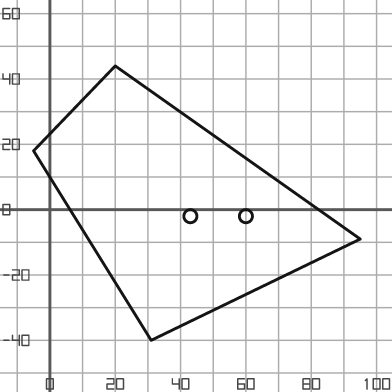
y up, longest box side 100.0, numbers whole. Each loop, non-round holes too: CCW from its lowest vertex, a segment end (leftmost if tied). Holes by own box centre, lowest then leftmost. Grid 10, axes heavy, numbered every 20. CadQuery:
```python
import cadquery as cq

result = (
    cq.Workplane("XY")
    .moveTo(31.0, -40.0)
    .lineTo(95.0, -9.0)
    .lineTo(20.0, 44.0)
    .lineTo(-5.0, 18.0)
    .close()
    .moveTo(43.0, -2.0)
    .circle(2.0)
    .moveTo(60.0, -2.0)
    .circle(2.0)
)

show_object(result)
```